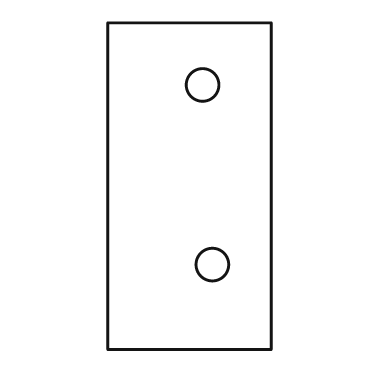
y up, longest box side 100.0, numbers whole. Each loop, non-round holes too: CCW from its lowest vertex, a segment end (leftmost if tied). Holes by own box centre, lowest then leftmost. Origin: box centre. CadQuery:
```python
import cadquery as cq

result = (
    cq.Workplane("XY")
    .moveTo(-25.0, -50.0)
    .lineTo(25.0, -50.0)
    .lineTo(25.0, 50.0)
    .lineTo(-25.0, 50.0)
    .close()
    .moveTo(7.0, -24.0)
    .circle(5.0)
    .moveTo(4.0, 31.0)
    .circle(5.0)
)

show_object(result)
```